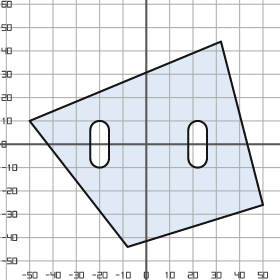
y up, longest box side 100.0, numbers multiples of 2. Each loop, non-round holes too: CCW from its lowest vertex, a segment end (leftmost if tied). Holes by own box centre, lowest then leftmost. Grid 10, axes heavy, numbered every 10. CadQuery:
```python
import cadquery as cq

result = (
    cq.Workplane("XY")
    .moveTo(-8.0, -44.0)
    .lineTo(50.0, -26.0)
    .lineTo(32.0, 44.0)
    .lineTo(-50.0, 10.0)
    .close()
    .moveTo(-24.0, -6.0)
    .threePointArc((-20.0, -10.0), (-16.0, -6.0))
    .lineTo(-16.0, 6.0)
    .threePointArc((-20.0, 10.0), (-24.0, 6.0))
    .close()
    .moveTo(18.0, -6.0)
    .threePointArc((22.0, -10.0), (26.0, -6.0))
    .lineTo(26.0, 6.0)
    .threePointArc((22.0, 10.0), (18.0, 6.0))
    .close()
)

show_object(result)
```